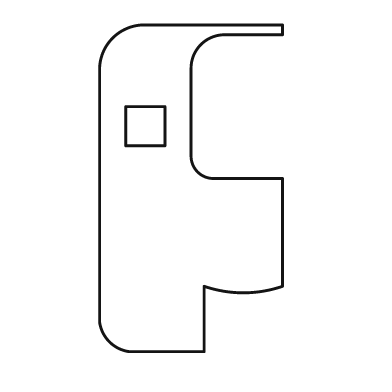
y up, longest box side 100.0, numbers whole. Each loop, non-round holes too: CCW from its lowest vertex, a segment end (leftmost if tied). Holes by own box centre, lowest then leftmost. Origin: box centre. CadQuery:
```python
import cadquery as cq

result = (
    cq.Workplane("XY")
    .moveTo(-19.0, -50.0)
    .lineTo(4.0, -50.0)
    .lineTo(4.0, -30.0)
    .threePointArc((16.0, -32.0), (28.0, -30.0))
    .lineTo(28.0, 3.0)
    .lineTo(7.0, 3.0)
    .threePointArc((2.0, 5.0), (0.0, 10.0))
    .lineTo(0.0, 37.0)
    .threePointArc((3.0, 44.0), (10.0, 47.0))
    .lineTo(28.0, 47.0)
    .lineTo(28.0, 50.0)
    .lineTo(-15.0, 50.0)
    .threePointArc((-24.0, 46.0), (-28.0, 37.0))
    .lineTo(-28.0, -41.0)
    .threePointArc((-25.0, -47.0), (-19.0, -50.0))
    .close()
    .moveTo(-20.0, 13.0)
    .lineTo(-8.0, 13.0)
    .lineTo(-8.0, 25.0)
    .lineTo(-20.0, 25.0)
    .close()
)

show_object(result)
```